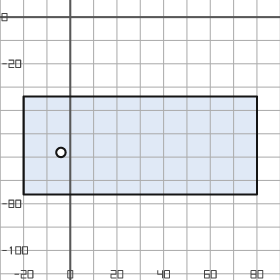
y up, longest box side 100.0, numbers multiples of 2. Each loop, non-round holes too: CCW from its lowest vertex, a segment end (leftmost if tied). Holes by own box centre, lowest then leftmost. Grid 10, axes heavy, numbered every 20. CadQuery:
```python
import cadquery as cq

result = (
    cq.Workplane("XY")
    .moveTo(-20.0, -76.0)
    .lineTo(80.0, -76.0)
    .lineTo(80.0, -34.0)
    .lineTo(-20.0, -34.0)
    .close()
    .moveTo(-4.0, -58.0)
    .circle(2.0)
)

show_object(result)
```